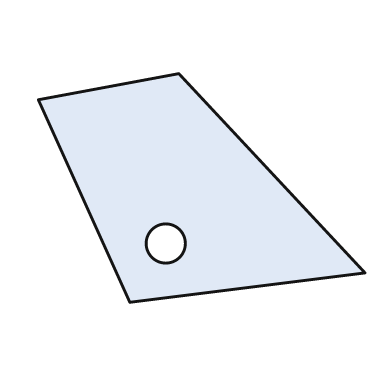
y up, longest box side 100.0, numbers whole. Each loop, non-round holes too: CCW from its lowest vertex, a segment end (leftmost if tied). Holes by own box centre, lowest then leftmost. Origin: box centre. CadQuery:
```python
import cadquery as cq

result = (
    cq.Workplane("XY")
    .moveTo(-22.0, -35.0)
    .lineTo(50.0, -26.0)
    .lineTo(-7.0, 35.0)
    .lineTo(-50.0, 27.0)
    .close()
    .moveTo(-11.0, -17.0)
    .circle(6.0)
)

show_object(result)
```